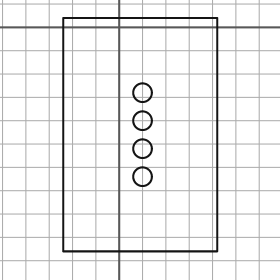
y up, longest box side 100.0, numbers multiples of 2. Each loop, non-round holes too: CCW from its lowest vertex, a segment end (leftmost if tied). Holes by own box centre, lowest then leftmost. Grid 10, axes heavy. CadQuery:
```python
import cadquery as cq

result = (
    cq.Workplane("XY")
    .moveTo(-24.0, -96.0)
    .lineTo(42.0, -96.0)
    .lineTo(42.0, 4.0)
    .lineTo(-24.0, 4.0)
    .close()
    .moveTo(10.0, -64.0)
    .circle(4.0)
    .moveTo(10.0, -52.0)
    .circle(4.0)
    .moveTo(10.0, -40.0)
    .circle(4.0)
    .moveTo(10.0, -28.0)
    .circle(4.0)
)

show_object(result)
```